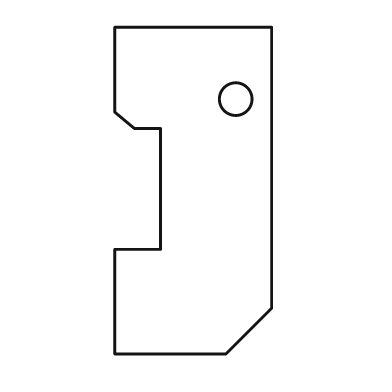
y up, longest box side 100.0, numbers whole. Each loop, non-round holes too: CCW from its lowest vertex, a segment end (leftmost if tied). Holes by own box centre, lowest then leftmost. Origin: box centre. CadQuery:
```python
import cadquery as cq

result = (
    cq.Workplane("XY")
    .moveTo(-24.0, -50.0)
    .lineTo(10.0, -50.0)
    .lineTo(24.0, -36.0)
    .lineTo(24.0, 50.0)
    .lineTo(-24.0, 50.0)
    .lineTo(-24.0, 24.0)
    .lineTo(-18.0, 19.0)
    .lineTo(-10.0, 19.0)
    .lineTo(-10.0, -18.0)
    .lineTo(-24.0, -18.0)
    .close()
    .moveTo(13.0, 28.0)
    .circle(5.0)
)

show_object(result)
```